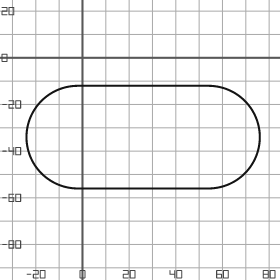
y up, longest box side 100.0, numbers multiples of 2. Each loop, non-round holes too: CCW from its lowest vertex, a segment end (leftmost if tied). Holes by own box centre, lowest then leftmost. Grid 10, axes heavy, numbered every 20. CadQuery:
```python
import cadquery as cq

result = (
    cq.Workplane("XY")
    .moveTo(-2.0, -56.0)
    .lineTo(54.0, -56.0)
    .threePointArc((76.0, -34.0), (54.0, -12.0))
    .lineTo(-2.0, -12.0)
    .threePointArc((-24.0, -34.0), (-2.0, -56.0))
    .close()
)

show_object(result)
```